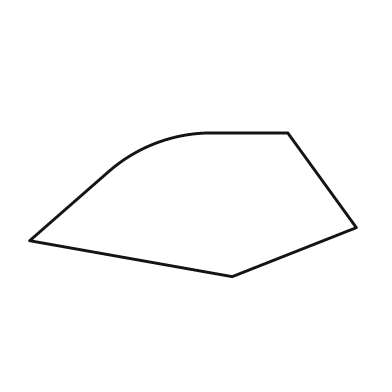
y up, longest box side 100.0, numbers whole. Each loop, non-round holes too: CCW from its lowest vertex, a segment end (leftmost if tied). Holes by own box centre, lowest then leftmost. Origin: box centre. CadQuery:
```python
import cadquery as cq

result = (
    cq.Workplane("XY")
    .moveTo(12.0, -22.0)
    .lineTo(50.0, -7.0)
    .lineTo(29.0, 22.0)
    .lineTo(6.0, 22.0)
    .threePointArc((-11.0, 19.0), (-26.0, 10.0))
    .lineTo(-50.0, -11.0)
    .close()
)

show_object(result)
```